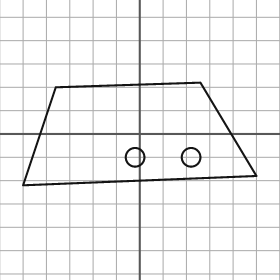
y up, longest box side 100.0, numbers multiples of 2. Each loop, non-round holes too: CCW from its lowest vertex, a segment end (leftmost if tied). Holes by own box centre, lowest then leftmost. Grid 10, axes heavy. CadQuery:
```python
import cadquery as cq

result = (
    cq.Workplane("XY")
    .moveTo(-50.0, -22.0)
    .lineTo(50.0, -18.0)
    .lineTo(26.0, 22.0)
    .lineTo(-36.0, 20.0)
    .close()
    .moveTo(-2.0, -10.0)
    .circle(4.0)
    .moveTo(22.0, -10.0)
    .circle(4.0)
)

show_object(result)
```